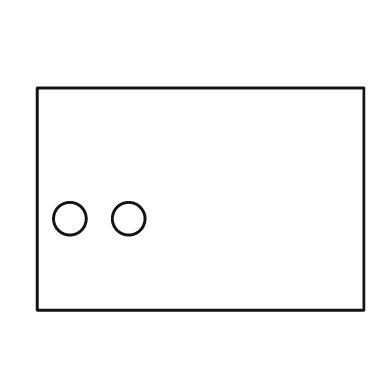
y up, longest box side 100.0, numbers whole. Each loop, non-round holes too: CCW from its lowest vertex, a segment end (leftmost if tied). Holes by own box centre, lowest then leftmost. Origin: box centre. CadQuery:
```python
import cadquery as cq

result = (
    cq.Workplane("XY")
    .moveTo(-50.0, -34.0)
    .lineTo(50.0, -34.0)
    .lineTo(50.0, 34.0)
    .lineTo(-50.0, 34.0)
    .close()
    .moveTo(-40.0, -6.0)
    .circle(5.0)
    .moveTo(-22.0, -6.0)
    .circle(5.0)
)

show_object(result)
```